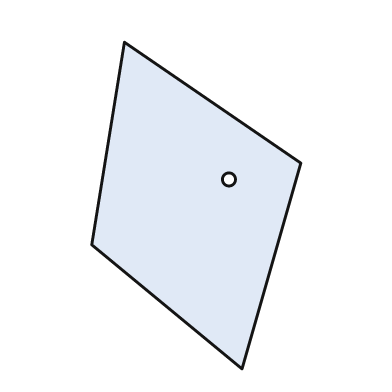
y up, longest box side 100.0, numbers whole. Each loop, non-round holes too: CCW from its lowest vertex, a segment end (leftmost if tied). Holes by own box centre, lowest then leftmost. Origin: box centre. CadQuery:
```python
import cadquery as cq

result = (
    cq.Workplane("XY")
    .moveTo(14.0, -50.0)
    .lineTo(32.0, 13.0)
    .lineTo(-22.0, 50.0)
    .lineTo(-32.0, -12.0)
    .close()
    .moveTo(10.0, 8.0)
    .circle(2.0)
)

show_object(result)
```